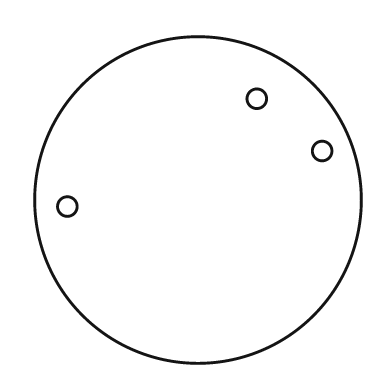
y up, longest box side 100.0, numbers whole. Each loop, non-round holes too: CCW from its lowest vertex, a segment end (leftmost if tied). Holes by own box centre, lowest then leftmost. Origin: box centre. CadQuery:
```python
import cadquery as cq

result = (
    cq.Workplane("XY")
    .moveTo(0.0, 0.0)
    .circle(50.0)
    .moveTo(-40.0, -2.0)
    .circle(3.0)
    .moveTo(38.0, 15.0)
    .circle(3.0)
    .moveTo(18.0, 31.0)
    .circle(3.0)
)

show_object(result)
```